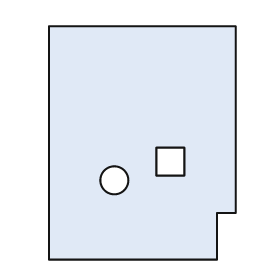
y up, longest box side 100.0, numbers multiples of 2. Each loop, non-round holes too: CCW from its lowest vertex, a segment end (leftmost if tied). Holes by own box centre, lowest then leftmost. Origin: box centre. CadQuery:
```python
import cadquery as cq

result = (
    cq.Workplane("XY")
    .moveTo(-40.0, -50.0)
    .lineTo(32.0, -50.0)
    .lineTo(32.0, -30.0)
    .lineTo(40.0, -30.0)
    .lineTo(40.0, 50.0)
    .lineTo(-40.0, 50.0)
    .close()
    .moveTo(-12.0, -16.0)
    .circle(6.0)
    .moveTo(6.0, -14.0)
    .lineTo(18.0, -14.0)
    .lineTo(18.0, -2.0)
    .lineTo(6.0, -2.0)
    .close()
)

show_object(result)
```